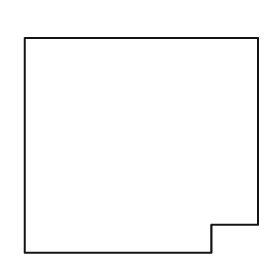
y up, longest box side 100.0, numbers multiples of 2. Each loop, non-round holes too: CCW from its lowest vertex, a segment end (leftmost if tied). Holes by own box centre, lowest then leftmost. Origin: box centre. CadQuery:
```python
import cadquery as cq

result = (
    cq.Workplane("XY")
    .moveTo(-50.0, -46.0)
    .lineTo(30.0, -46.0)
    .lineTo(30.0, -34.0)
    .lineTo(50.0, -34.0)
    .lineTo(50.0, 46.0)
    .lineTo(-50.0, 46.0)
    .close()
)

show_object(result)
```